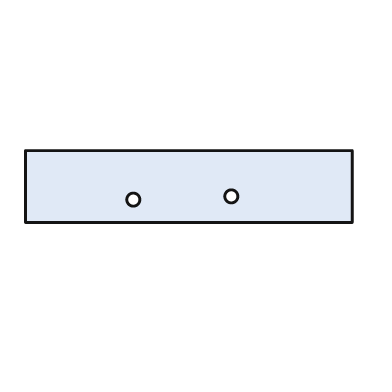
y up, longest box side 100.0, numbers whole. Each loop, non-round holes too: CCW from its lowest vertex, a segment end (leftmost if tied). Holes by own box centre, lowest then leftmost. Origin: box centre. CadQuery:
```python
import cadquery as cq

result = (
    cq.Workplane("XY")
    .moveTo(-50.0, -11.0)
    .lineTo(50.0, -11.0)
    .lineTo(50.0, 11.0)
    .lineTo(-50.0, 11.0)
    .close()
    .moveTo(-17.0, -4.0)
    .circle(2.0)
    .moveTo(13.0, -3.0)
    .circle(2.0)
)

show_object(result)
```